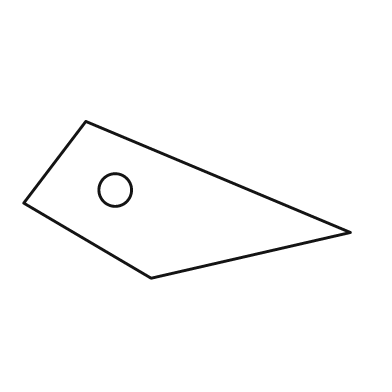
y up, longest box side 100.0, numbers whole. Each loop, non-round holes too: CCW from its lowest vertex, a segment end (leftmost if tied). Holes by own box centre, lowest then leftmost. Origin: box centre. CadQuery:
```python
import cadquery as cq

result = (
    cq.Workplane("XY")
    .moveTo(-11.0, -24.0)
    .lineTo(50.0, -10.0)
    .lineTo(-31.0, 24.0)
    .lineTo(-50.0, -1.0)
    .close()
    .moveTo(-22.0, 3.0)
    .circle(5.0)
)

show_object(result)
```